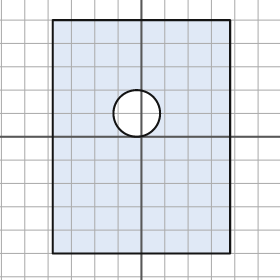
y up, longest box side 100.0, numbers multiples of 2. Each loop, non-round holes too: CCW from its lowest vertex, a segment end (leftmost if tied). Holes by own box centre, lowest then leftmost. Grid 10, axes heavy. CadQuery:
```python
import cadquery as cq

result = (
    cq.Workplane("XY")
    .moveTo(-38.0, -50.0)
    .lineTo(38.0, -50.0)
    .lineTo(38.0, 50.0)
    .lineTo(-38.0, 50.0)
    .close()
    .moveTo(-2.0, 10.0)
    .circle(10.0)
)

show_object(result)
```